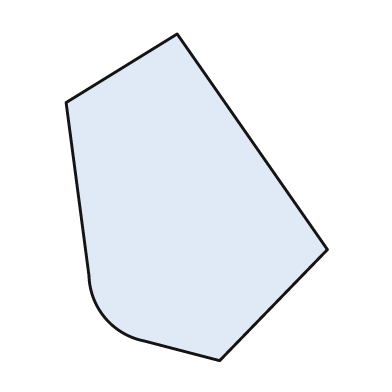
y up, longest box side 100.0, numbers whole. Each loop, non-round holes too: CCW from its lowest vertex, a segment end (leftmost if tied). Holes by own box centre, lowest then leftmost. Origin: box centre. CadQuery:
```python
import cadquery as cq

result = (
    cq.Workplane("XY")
    .moveTo(7.0, -50.0)
    .lineTo(40.0, -16.0)
    .lineTo(-6.0, 50.0)
    .lineTo(-40.0, 29.0)
    .lineTo(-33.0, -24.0)
    .threePointArc((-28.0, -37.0), (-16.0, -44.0))
    .close()
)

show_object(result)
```